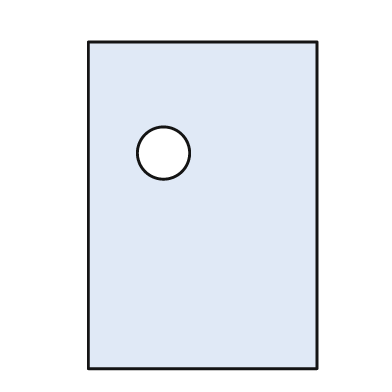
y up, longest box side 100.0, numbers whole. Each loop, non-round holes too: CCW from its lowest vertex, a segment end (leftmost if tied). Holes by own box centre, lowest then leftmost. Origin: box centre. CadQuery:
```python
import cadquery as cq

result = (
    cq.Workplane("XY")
    .moveTo(-35.0, -50.0)
    .lineTo(35.0, -50.0)
    .lineTo(35.0, 50.0)
    .lineTo(-35.0, 50.0)
    .close()
    .moveTo(-12.0, 16.0)
    .circle(8.0)
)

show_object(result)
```